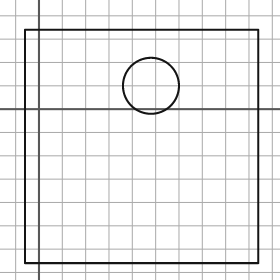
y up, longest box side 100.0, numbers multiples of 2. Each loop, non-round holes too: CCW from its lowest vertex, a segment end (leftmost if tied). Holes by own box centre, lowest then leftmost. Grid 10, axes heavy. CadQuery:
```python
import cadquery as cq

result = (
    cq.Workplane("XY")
    .moveTo(-6.0, -66.0)
    .lineTo(94.0, -66.0)
    .lineTo(94.0, 34.0)
    .lineTo(-6.0, 34.0)
    .close()
    .moveTo(48.0, 10.0)
    .circle(12.0)
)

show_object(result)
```